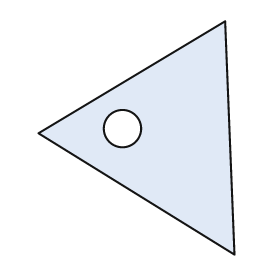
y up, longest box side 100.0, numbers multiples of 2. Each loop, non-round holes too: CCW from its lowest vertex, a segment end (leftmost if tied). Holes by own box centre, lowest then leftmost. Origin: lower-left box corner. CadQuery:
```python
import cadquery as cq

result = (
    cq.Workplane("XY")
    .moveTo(84.0, 0.0)
    .lineTo(80.0, 100.0)
    .lineTo(0.0, 52.0)
    .close()
    .moveTo(36.0, 54.0)
    .circle(8.0)
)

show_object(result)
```